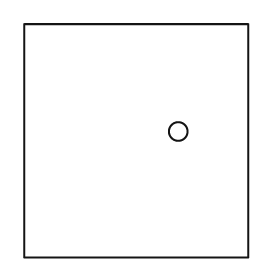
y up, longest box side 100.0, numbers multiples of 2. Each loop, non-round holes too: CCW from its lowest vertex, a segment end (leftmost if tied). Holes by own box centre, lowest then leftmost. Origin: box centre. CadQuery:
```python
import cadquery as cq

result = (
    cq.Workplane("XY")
    .moveTo(-48.0, -50.0)
    .lineTo(48.0, -50.0)
    .lineTo(48.0, 50.0)
    .lineTo(-48.0, 50.0)
    .close()
    .moveTo(18.0, 4.0)
    .circle(4.0)
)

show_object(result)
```